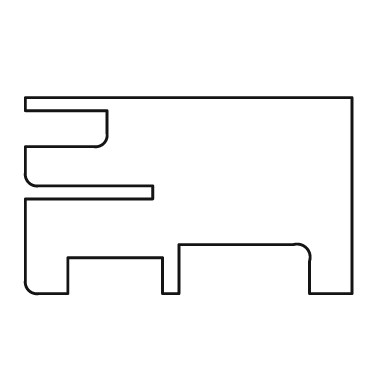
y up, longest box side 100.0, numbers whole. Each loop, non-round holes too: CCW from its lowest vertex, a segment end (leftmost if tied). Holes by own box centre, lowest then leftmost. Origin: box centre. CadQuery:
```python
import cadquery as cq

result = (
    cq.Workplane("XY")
    .moveTo(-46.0, -30.0)
    .lineTo(-37.0, -30.0)
    .lineTo(-37.0, -19.0)
    .lineTo(-8.0, -19.0)
    .lineTo(-8.0, -30.0)
    .lineTo(-3.0, -30.0)
    .lineTo(-3.0, -15.0)
    .lineTo(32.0, -15.0)
    .threePointArc((36.0, -16.0), (37.0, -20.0))
    .lineTo(37.0, -30.0)
    .lineTo(50.0, -30.0)
    .lineTo(50.0, 30.0)
    .lineTo(-50.0, 30.0)
    .lineTo(-50.0, 26.0)
    .lineTo(-25.0, 26.0)
    .lineTo(-25.0, 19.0)
    .threePointArc((-26.0, 16.0), (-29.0, 15.0))
    .lineTo(-50.0, 15.0)
    .lineTo(-50.0, 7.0)
    .threePointArc((-49.0, 4.0), (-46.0, 3.0))
    .lineTo(-11.0, 3.0)
    .lineTo(-11.0, -1.0)
    .lineTo(-50.0, -1.0)
    .lineTo(-50.0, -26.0)
    .threePointArc((-49.0, -29.0), (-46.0, -30.0))
    .close()
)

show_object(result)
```